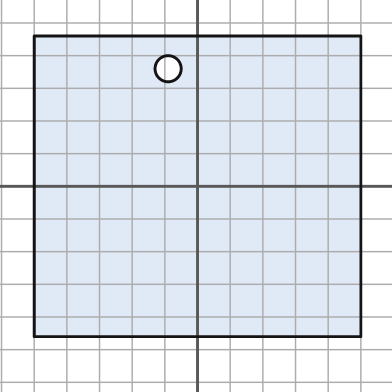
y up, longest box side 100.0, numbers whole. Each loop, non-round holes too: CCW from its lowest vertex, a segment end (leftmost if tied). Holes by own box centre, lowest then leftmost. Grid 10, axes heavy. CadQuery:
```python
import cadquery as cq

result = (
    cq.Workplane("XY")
    .moveTo(-50.0, -46.0)
    .lineTo(50.0, -46.0)
    .lineTo(50.0, 46.0)
    .lineTo(-50.0, 46.0)
    .close()
    .moveTo(-9.0, 36.0)
    .circle(4.0)
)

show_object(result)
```